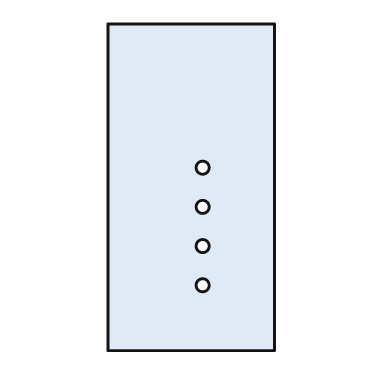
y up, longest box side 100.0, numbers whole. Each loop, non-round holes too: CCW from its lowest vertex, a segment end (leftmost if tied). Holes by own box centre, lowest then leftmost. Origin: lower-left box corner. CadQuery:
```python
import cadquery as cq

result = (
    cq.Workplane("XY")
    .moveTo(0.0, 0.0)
    .lineTo(51.0, 0.0)
    .lineTo(51.0, 100.0)
    .lineTo(0.0, 100.0)
    .close()
    .moveTo(29.0, 20.0)
    .circle(2.0)
    .moveTo(29.0, 32.0)
    .circle(2.0)
    .moveTo(29.0, 44.0)
    .circle(2.0)
    .moveTo(29.0, 56.0)
    .circle(2.0)
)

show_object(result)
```